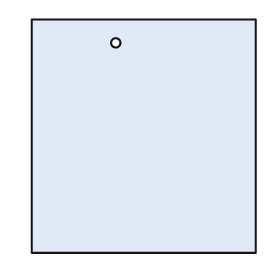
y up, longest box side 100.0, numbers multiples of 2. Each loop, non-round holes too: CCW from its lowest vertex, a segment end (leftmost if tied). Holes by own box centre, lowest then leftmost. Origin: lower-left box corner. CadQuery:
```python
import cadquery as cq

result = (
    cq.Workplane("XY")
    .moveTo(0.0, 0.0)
    .lineTo(96.0, 0.0)
    .lineTo(96.0, 100.0)
    .lineTo(0.0, 100.0)
    .close()
    .moveTo(36.0, 90.0)
    .circle(2.0)
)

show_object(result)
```